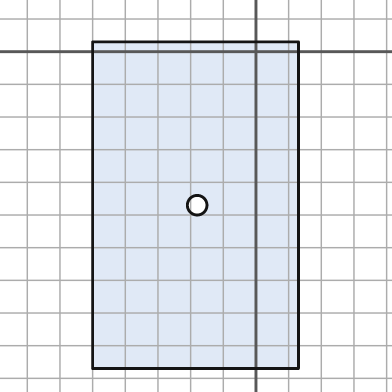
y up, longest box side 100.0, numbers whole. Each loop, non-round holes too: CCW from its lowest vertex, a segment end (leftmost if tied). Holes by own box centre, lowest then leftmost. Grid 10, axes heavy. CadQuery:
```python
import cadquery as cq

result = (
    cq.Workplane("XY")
    .moveTo(-50.0, -97.0)
    .lineTo(13.0, -97.0)
    .lineTo(13.0, 3.0)
    .lineTo(-50.0, 3.0)
    .close()
    .moveTo(-18.0, -47.0)
    .circle(3.0)
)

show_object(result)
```